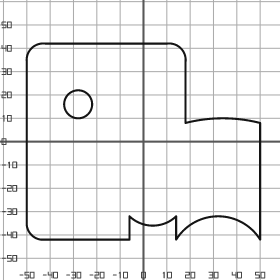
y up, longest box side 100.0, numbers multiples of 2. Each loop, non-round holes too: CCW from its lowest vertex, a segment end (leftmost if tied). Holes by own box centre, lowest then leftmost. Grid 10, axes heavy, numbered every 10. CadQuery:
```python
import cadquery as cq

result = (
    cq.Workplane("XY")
    .moveTo(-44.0, -42.0)
    .lineTo(-6.0, -42.0)
    .lineTo(-6.0, -32.0)
    .threePointArc((4.0, -36.0), (14.0, -32.0))
    .lineTo(14.0, -42.0)
    .threePointArc((32.0, -32.0), (50.0, -42.0))
    .lineTo(50.0, 8.0)
    .threePointArc((34.0, 10.0), (18.0, 8.0))
    .lineTo(18.0, 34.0)
    .threePointArc((16.0, 40.0), (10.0, 42.0))
    .lineTo(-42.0, 42.0)
    .threePointArc((-48.0, 40.0), (-50.0, 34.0))
    .lineTo(-50.0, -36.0)
    .threePointArc((-48.0, -40.0), (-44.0, -42.0))
    .close()
    .moveTo(-28.0, 16.0)
    .circle(6.0)
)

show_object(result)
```